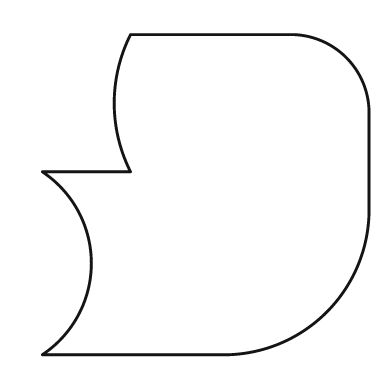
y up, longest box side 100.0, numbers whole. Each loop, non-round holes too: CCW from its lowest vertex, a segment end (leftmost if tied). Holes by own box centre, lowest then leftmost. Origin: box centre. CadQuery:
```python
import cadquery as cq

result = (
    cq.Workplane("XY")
    .moveTo(-50.0, -49.0)
    .lineTo(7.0, -49.0)
    .threePointArc((37.0, -36.0), (50.0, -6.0))
    .lineTo(50.0, 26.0)
    .threePointArc((43.0, 42.0), (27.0, 49.0))
    .lineTo(-23.0, 49.0)
    .threePointArc((-28.0, 28.0), (-23.0, 7.0))
    .lineTo(-50.0, 7.0)
    .threePointArc((-35.0, -21.0), (-50.0, -49.0))
    .close()
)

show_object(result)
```